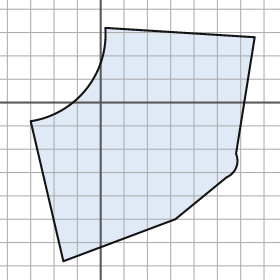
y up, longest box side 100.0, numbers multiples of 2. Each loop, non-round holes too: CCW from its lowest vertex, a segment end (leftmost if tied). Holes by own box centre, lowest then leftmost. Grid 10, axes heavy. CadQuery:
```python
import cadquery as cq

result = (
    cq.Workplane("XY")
    .moveTo(-16.0, -68.0)
    .lineTo(32.0, -50.0)
    .lineTo(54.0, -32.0)
    .threePointArc((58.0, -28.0), (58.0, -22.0))
    .lineTo(66.0, 28.0)
    .lineTo(2.0, 32.0)
    .threePointArc((-6.0, 6.0), (-30.0, -8.0))
    .close()
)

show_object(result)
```